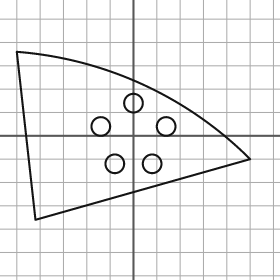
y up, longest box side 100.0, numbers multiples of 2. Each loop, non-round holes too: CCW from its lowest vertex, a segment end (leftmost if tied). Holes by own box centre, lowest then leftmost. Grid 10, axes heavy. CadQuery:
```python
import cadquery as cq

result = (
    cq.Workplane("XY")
    .moveTo(-42.0, -36.0)
    .lineTo(50.0, -10.0)
    .threePointArc((4.0, 22.0), (-50.0, 36.0))
    .close()
    .moveTo(-8.0, -12.0)
    .circle(4.0)
    .moveTo(8.0, -12.0)
    .circle(4.0)
    .moveTo(-14.0, 4.0)
    .circle(4.0)
    .moveTo(14.0, 4.0)
    .circle(4.0)
    .moveTo(0.0, 14.0)
    .circle(4.0)
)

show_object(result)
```